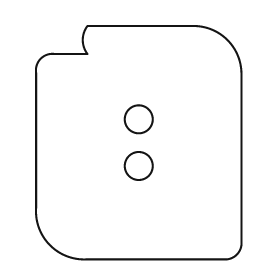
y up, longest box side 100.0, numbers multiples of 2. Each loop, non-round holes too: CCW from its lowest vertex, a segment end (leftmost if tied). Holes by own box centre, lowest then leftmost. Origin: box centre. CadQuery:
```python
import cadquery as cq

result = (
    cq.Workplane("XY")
    .moveTo(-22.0, -50.0)
    .lineTo(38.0, -50.0)
    .threePointArc((42.0, -48.0), (44.0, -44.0))
    .lineTo(44.0, 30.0)
    .threePointArc((38.0, 44.0), (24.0, 50.0))
    .lineTo(-22.0, 50.0)
    .threePointArc((-24.0, 44.0), (-22.0, 38.0))
    .lineTo(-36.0, 38.0)
    .threePointArc((-42.0, 36.0), (-44.0, 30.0))
    .lineTo(-44.0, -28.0)
    .threePointArc((-38.0, -44.0), (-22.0, -50.0))
    .close()
    .moveTo(0.0, -10.0)
    .circle(6.0)
    .moveTo(0.0, 10.0)
    .circle(6.0)
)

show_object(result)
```